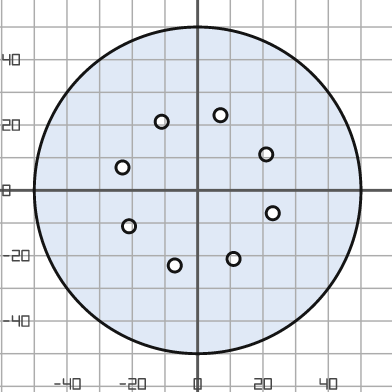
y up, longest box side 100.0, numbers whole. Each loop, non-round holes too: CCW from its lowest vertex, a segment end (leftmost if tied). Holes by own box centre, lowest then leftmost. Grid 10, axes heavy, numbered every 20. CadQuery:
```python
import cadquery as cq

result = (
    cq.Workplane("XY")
    .moveTo(0.0, 0.0)
    .circle(50.0)
    .moveTo(-7.0, -23.0)
    .circle(2.0)
    .moveTo(11.0, -21.0)
    .circle(2.0)
    .moveTo(-21.0, -11.0)
    .circle(2.0)
    .moveTo(23.0, -7.0)
    .circle(2.0)
    .moveTo(-23.0, 7.0)
    .circle(2.0)
    .moveTo(21.0, 11.0)
    .circle(2.0)
    .moveTo(-11.0, 21.0)
    .circle(2.0)
    .moveTo(7.0, 23.0)
    .circle(2.0)
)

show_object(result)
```